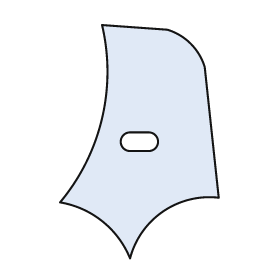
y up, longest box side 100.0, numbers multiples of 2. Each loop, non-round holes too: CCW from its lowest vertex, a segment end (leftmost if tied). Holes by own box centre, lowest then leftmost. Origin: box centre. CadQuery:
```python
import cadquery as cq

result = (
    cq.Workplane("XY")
    .moveTo(-4.0, -50.0)
    .threePointArc((10.0, -30.0), (34.0, -24.0))
    .lineTo(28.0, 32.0)
    .threePointArc((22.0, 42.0), (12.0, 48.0))
    .lineTo(-16.0, 50.0)
    .threePointArc((-16.0, 10.0), (-34.0, -26.0))
    .threePointArc((-16.0, -34.0), (-4.0, -50.0))
    .close()
    .moveTo(-4.0, -4.0)
    .lineTo(4.0, -4.0)
    .threePointArc((8.0, 0.0), (4.0, 4.0))
    .lineTo(-4.0, 4.0)
    .threePointArc((-8.0, 0.0), (-4.0, -4.0))
    .close()
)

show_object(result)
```